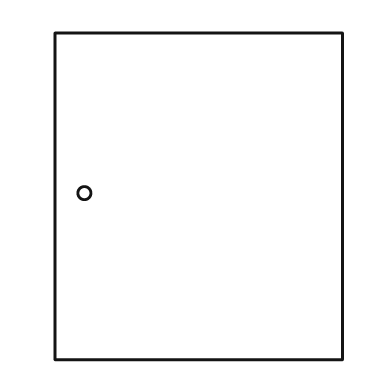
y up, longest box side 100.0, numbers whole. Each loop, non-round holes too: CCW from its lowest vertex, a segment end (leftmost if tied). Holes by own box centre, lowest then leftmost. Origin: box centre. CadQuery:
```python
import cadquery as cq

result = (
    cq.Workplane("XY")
    .moveTo(-44.0, -50.0)
    .lineTo(44.0, -50.0)
    .lineTo(44.0, 50.0)
    .lineTo(-44.0, 50.0)
    .close()
    .moveTo(-35.0, 1.0)
    .circle(2.0)
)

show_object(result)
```